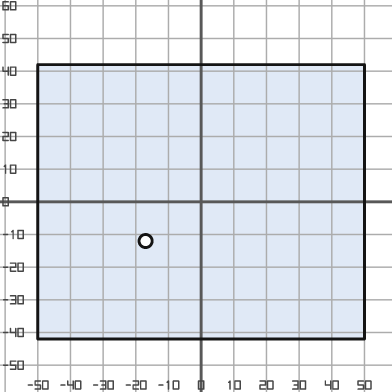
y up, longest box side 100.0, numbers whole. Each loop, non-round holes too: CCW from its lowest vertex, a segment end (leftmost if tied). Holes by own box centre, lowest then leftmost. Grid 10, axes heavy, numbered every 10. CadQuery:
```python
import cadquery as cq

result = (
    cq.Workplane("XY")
    .moveTo(-50.0, -42.0)
    .lineTo(50.0, -42.0)
    .lineTo(50.0, 42.0)
    .lineTo(-50.0, 42.0)
    .close()
    .moveTo(-17.0, -12.0)
    .circle(2.0)
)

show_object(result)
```